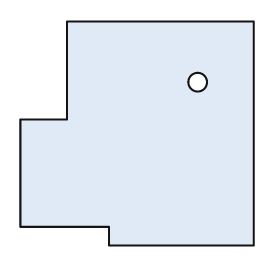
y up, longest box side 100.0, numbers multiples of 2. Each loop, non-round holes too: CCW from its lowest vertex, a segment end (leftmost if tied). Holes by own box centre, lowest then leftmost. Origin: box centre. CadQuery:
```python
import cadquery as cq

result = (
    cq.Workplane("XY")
    .moveTo(-12.0, -48.0)
    .lineTo(50.0, -48.0)
    .lineTo(50.0, 48.0)
    .lineTo(-30.0, 48.0)
    .lineTo(-30.0, 6.0)
    .lineTo(-50.0, 6.0)
    .lineTo(-50.0, -40.0)
    .lineTo(-12.0, -40.0)
    .close()
    .moveTo(26.0, 22.0)
    .circle(4.0)
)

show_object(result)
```